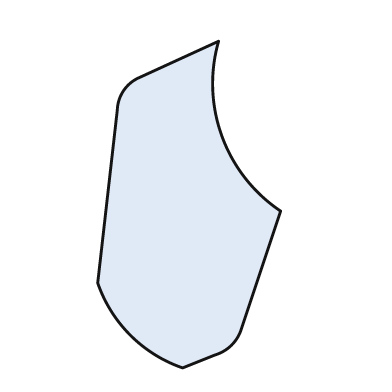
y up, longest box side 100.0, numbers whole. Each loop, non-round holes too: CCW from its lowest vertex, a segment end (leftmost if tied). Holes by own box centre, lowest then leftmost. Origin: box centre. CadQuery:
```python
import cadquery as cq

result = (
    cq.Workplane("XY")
    .moveTo(-2.0, -50.0)
    .lineTo(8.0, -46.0)
    .threePointArc((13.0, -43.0), (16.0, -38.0))
    .lineTo(28.0, -2.0)
    .threePointArc((10.0, 21.0), (9.0, 50.0))
    .lineTo(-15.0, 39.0)
    .threePointArc((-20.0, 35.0), (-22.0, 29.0))
    .lineTo(-28.0, -24.0)
    .threePointArc((-18.0, -40.0), (-2.0, -50.0))
    .close()
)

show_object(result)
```